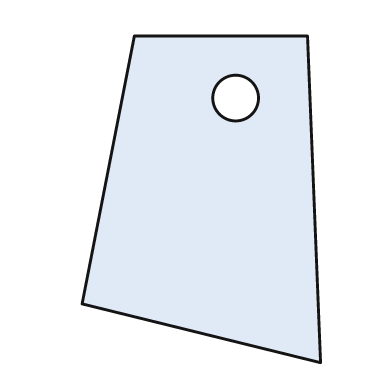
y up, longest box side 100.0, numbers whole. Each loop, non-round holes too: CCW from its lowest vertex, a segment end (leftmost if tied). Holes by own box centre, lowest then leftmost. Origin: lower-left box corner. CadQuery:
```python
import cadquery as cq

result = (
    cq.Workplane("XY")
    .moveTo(73.0, 0.0)
    .lineTo(69.0, 100.0)
    .lineTo(16.0, 100.0)
    .lineTo(0.0, 18.0)
    .close()
    .moveTo(47.0, 81.0)
    .circle(7.0)
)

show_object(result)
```